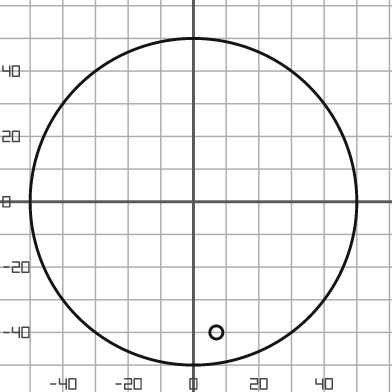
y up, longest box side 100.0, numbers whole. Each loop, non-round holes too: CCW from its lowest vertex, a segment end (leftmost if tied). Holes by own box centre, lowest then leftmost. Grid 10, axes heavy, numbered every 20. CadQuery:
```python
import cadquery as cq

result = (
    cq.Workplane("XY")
    .moveTo(0.0, 0.0)
    .circle(50.0)
    .moveTo(7.0, -40.0)
    .circle(2.0)
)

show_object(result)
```